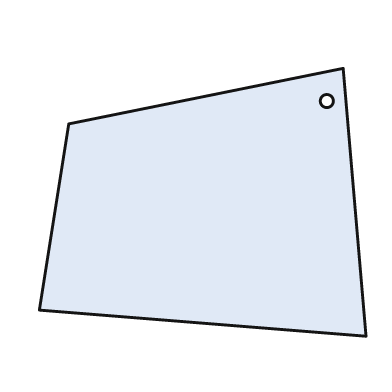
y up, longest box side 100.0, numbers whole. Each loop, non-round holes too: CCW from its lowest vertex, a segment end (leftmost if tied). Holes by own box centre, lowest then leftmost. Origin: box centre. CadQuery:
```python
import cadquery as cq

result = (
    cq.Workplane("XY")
    .moveTo(50.0, -41.0)
    .lineTo(43.0, 41.0)
    .lineTo(-41.0, 24.0)
    .lineTo(-50.0, -33.0)
    .close()
    .moveTo(38.0, 31.0)
    .circle(2.0)
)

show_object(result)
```